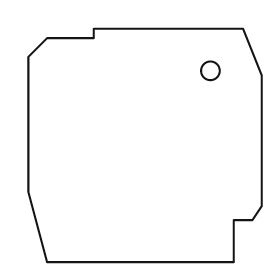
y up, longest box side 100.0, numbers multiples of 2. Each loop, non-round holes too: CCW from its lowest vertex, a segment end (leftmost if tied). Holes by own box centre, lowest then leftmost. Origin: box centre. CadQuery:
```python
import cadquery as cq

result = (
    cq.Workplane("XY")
    .moveTo(-42.0, -50.0)
    .lineTo(38.0, -50.0)
    .lineTo(38.0, -32.0)
    .lineTo(46.0, -32.0)
    .lineTo(50.0, -26.0)
    .lineTo(50.0, 30.0)
    .lineTo(42.0, 50.0)
    .lineTo(-22.0, 50.0)
    .lineTo(-22.0, 46.0)
    .lineTo(-42.0, 46.0)
    .lineTo(-50.0, 38.0)
    .lineTo(-50.0, -20.0)
    .close()
    .moveTo(28.0, 32.0)
    .circle(4.0)
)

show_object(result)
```